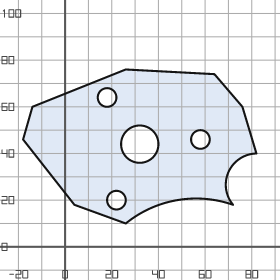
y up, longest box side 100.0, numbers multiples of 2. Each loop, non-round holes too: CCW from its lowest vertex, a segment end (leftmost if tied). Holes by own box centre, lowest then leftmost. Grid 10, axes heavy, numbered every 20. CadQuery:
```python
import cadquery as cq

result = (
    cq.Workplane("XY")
    .moveTo(26.0, 10.0)
    .threePointArc((48.0, 20.0), (72.0, 18.0))
    .threePointArc((70.0, 32.0), (82.0, 40.0))
    .lineTo(76.0, 60.0)
    .lineTo(64.0, 74.0)
    .lineTo(26.0, 76.0)
    .lineTo(-14.0, 60.0)
    .lineTo(-18.0, 46.0)
    .lineTo(4.0, 18.0)
    .close()
    .moveTo(22.0, 20.0)
    .circle(4.0)
    .moveTo(32.0, 44.0)
    .circle(8.0)
    .moveTo(58.0, 46.0)
    .circle(4.0)
    .moveTo(18.0, 64.0)
    .circle(4.0)
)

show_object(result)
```